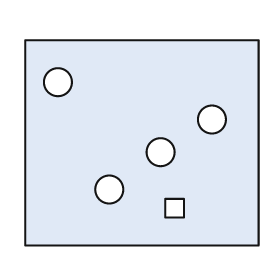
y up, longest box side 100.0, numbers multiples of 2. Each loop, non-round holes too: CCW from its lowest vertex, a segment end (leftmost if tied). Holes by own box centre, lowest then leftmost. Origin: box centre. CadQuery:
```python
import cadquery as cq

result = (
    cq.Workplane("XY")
    .moveTo(-50.0, -44.0)
    .lineTo(50.0, -44.0)
    .lineTo(50.0, 44.0)
    .lineTo(-50.0, 44.0)
    .close()
    .moveTo(10.0, -32.0)
    .lineTo(18.0, -32.0)
    .lineTo(18.0, -24.0)
    .lineTo(10.0, -24.0)
    .close()
    .moveTo(-14.0, -20.0)
    .circle(6.0)
    .moveTo(8.0, -4.0)
    .circle(6.0)
    .moveTo(30.0, 10.0)
    .circle(6.0)
    .moveTo(-36.0, 26.0)
    .circle(6.0)
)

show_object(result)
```